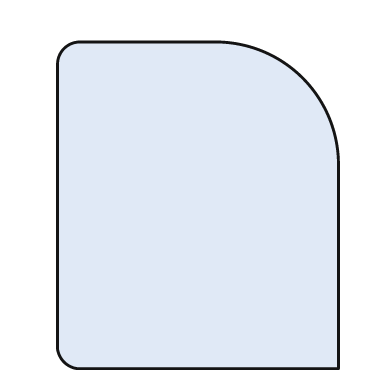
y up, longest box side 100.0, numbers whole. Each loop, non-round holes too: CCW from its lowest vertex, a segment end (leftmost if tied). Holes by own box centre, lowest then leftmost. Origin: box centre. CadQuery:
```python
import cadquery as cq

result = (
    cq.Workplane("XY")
    .moveTo(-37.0, -50.0)
    .lineTo(43.0, -50.0)
    .lineTo(43.0, 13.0)
    .threePointArc((32.0, 39.0), (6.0, 50.0))
    .lineTo(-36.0, 50.0)
    .threePointArc((-41.0, 48.0), (-43.0, 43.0))
    .lineTo(-43.0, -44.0)
    .threePointArc((-41.0, -48.0), (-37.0, -50.0))
    .close()
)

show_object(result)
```